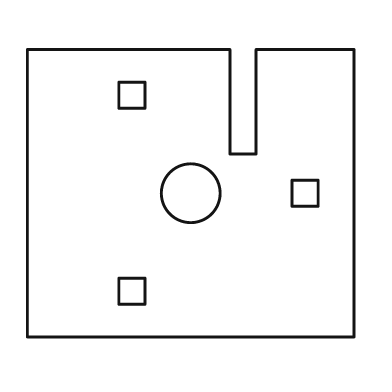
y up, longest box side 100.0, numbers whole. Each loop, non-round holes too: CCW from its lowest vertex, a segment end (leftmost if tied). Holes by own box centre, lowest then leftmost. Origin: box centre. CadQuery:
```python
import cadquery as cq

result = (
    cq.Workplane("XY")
    .moveTo(-50.0, -44.0)
    .lineTo(50.0, -44.0)
    .lineTo(50.0, 44.0)
    .lineTo(20.0, 44.0)
    .lineTo(20.0, 12.0)
    .lineTo(12.0, 12.0)
    .lineTo(12.0, 44.0)
    .lineTo(-50.0, 44.0)
    .close()
    .moveTo(-22.0, -34.0)
    .lineTo(-14.0, -34.0)
    .lineTo(-14.0, -26.0)
    .lineTo(-22.0, -26.0)
    .close()
    .moveTo(0.0, 0.0)
    .circle(9.0)
    .moveTo(31.0, -4.0)
    .lineTo(39.0, -4.0)
    .lineTo(39.0, 4.0)
    .lineTo(31.0, 4.0)
    .close()
    .moveTo(-22.0, 26.0)
    .lineTo(-14.0, 26.0)
    .lineTo(-14.0, 34.0)
    .lineTo(-22.0, 34.0)
    .close()
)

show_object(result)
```